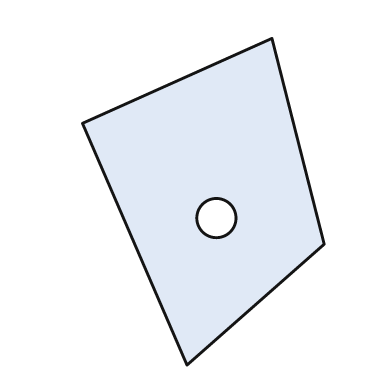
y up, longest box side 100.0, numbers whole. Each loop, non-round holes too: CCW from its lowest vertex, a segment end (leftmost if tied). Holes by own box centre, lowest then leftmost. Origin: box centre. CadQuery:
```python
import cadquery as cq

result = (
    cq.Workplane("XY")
    .moveTo(-5.0, -50.0)
    .lineTo(37.0, -13.0)
    .lineTo(21.0, 50.0)
    .lineTo(-37.0, 24.0)
    .close()
    .moveTo(4.0, -5.0)
    .circle(6.0)
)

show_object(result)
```